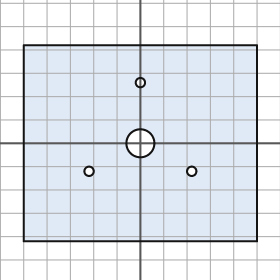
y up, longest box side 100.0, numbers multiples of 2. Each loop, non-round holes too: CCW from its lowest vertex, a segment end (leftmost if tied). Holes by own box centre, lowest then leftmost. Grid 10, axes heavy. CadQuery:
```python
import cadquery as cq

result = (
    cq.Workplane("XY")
    .moveTo(-50.0, -42.0)
    .lineTo(50.0, -42.0)
    .lineTo(50.0, 42.0)
    .lineTo(-50.0, 42.0)
    .close()
    .moveTo(-22.0, -12.0)
    .circle(2.0)
    .moveTo(22.0, -12.0)
    .circle(2.0)
    .moveTo(0.0, 0.0)
    .circle(6.0)
    .moveTo(0.0, 26.0)
    .circle(2.0)
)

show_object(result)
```